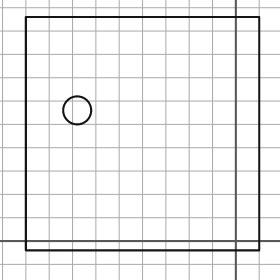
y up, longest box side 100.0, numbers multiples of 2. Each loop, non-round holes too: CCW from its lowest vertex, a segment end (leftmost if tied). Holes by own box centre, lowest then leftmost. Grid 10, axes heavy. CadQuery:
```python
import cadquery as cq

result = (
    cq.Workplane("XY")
    .moveTo(-90.0, -4.0)
    .lineTo(10.0, -4.0)
    .lineTo(10.0, 96.0)
    .lineTo(-90.0, 96.0)
    .close()
    .moveTo(-68.0, 56.0)
    .circle(6.0)
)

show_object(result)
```